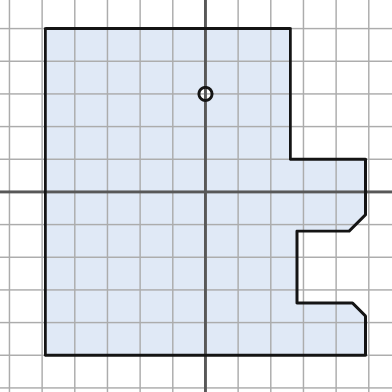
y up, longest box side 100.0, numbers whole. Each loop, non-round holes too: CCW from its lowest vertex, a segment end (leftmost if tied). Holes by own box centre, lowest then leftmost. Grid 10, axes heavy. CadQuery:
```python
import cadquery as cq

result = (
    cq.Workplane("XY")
    .moveTo(-49.0, -50.0)
    .lineTo(49.0, -50.0)
    .lineTo(49.0, -38.0)
    .lineTo(45.0, -34.0)
    .lineTo(28.0, -34.0)
    .lineTo(28.0, -12.0)
    .lineTo(44.0, -12.0)
    .lineTo(49.0, -7.0)
    .lineTo(49.0, 10.0)
    .lineTo(26.0, 10.0)
    .lineTo(26.0, 50.0)
    .lineTo(-49.0, 50.0)
    .close()
    .moveTo(0.0, 30.0)
    .circle(2.0)
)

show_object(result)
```